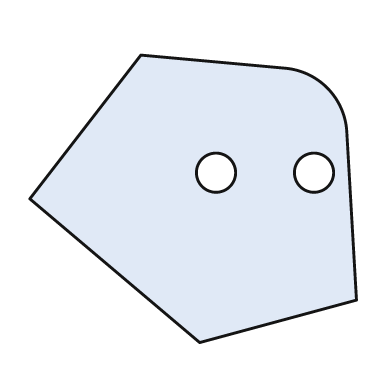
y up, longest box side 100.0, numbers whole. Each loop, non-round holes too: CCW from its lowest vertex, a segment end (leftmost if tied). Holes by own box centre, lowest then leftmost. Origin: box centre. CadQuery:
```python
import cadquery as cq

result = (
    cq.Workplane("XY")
    .moveTo(2.0, -44.0)
    .lineTo(50.0, -31.0)
    .lineTo(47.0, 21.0)
    .threePointArc((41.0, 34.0), (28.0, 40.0))
    .lineTo(-16.0, 44.0)
    .lineTo(-50.0, 0.0)
    .close()
    .moveTo(7.0, 8.0)
    .circle(6.0)
    .moveTo(37.0, 8.0)
    .circle(6.0)
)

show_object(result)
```